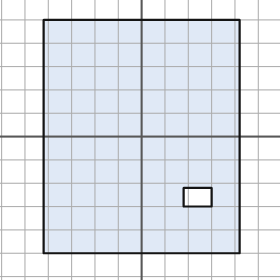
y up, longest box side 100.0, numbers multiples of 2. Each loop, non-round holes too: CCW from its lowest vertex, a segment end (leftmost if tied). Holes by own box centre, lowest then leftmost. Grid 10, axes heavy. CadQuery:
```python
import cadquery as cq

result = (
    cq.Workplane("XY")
    .moveTo(-42.0, -50.0)
    .lineTo(42.0, -50.0)
    .lineTo(42.0, 50.0)
    .lineTo(-42.0, 50.0)
    .close()
    .moveTo(18.0, -30.0)
    .lineTo(30.0, -30.0)
    .lineTo(30.0, -22.0)
    .lineTo(18.0, -22.0)
    .close()
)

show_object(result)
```